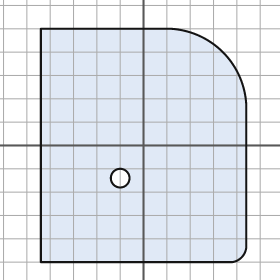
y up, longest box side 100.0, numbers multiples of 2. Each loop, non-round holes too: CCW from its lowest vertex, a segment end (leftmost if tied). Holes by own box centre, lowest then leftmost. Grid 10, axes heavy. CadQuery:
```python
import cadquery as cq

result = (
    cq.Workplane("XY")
    .moveTo(-44.0, -50.0)
    .lineTo(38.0, -50.0)
    .threePointArc((42.0, -48.0), (44.0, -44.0))
    .lineTo(44.0, 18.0)
    .threePointArc((34.0, 40.0), (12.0, 50.0))
    .lineTo(-44.0, 50.0)
    .close()
    .moveTo(-10.0, -14.0)
    .circle(4.0)
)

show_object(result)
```